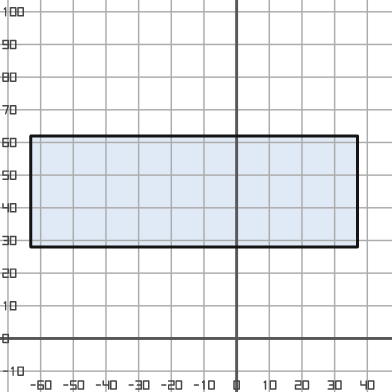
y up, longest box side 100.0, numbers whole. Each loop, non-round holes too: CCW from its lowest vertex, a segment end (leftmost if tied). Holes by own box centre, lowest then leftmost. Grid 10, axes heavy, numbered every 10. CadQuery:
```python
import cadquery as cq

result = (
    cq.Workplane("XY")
    .moveTo(-63.0, 28.0)
    .lineTo(37.0, 28.0)
    .lineTo(37.0, 62.0)
    .lineTo(-63.0, 62.0)
    .close()
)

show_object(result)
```